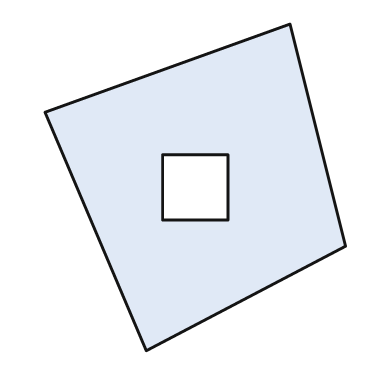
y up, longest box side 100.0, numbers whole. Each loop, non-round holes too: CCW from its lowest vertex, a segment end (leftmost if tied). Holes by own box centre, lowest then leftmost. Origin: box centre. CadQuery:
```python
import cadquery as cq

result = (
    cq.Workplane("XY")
    .moveTo(-15.0, -50.0)
    .lineTo(46.0, -18.0)
    .lineTo(29.0, 50.0)
    .lineTo(-46.0, 23.0)
    .close()
    .moveTo(-10.0, -10.0)
    .lineTo(10.0, -10.0)
    .lineTo(10.0, 10.0)
    .lineTo(-10.0, 10.0)
    .close()
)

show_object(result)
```